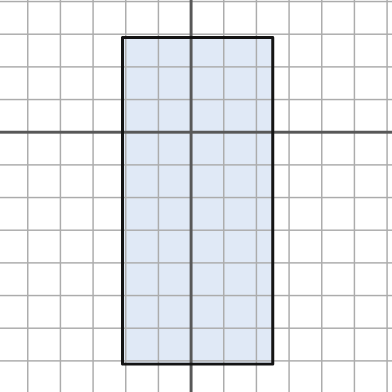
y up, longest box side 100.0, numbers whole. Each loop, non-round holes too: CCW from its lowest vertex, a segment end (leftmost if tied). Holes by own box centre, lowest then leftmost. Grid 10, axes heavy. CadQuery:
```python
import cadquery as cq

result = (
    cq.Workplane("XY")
    .moveTo(-21.0, -71.0)
    .lineTo(25.0, -71.0)
    .lineTo(25.0, 29.0)
    .lineTo(-21.0, 29.0)
    .close()
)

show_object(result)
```